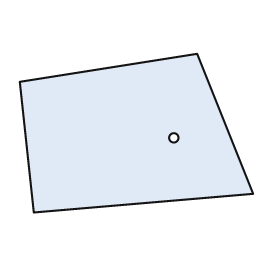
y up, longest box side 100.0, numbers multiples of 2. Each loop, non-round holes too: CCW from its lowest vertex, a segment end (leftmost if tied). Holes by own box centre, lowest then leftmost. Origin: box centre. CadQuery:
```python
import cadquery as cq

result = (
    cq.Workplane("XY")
    .moveTo(-44.0, -34.0)
    .lineTo(50.0, -26.0)
    .lineTo(26.0, 34.0)
    .lineTo(-50.0, 22.0)
    .close()
    .moveTo(16.0, -2.0)
    .circle(2.0)
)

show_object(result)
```